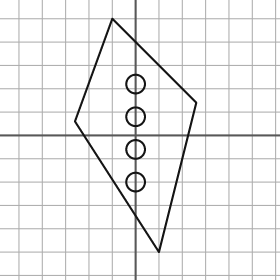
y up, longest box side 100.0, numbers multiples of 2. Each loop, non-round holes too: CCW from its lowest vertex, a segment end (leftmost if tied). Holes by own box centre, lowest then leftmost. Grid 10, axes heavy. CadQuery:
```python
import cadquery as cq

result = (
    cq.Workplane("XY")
    .moveTo(10.0, -50.0)
    .lineTo(26.0, 14.0)
    .lineTo(-10.0, 50.0)
    .lineTo(-26.0, 6.0)
    .close()
    .moveTo(0.0, -20.0)
    .circle(4.0)
    .moveTo(0.0, -6.0)
    .circle(4.0)
    .moveTo(0.0, 8.0)
    .circle(4.0)
    .moveTo(0.0, 22.0)
    .circle(4.0)
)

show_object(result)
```